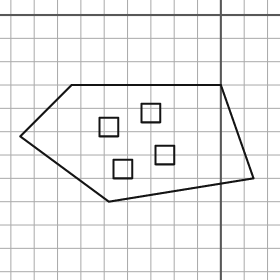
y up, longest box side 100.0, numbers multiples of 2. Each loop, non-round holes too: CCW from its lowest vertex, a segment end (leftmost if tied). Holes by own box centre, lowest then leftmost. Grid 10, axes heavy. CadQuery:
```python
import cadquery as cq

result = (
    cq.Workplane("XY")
    .moveTo(-48.0, -80.0)
    .lineTo(14.0, -70.0)
    .lineTo(0.0, -30.0)
    .lineTo(-64.0, -30.0)
    .lineTo(-86.0, -52.0)
    .close()
    .moveTo(-46.0, -70.0)
    .lineTo(-38.0, -70.0)
    .lineTo(-38.0, -62.0)
    .lineTo(-46.0, -62.0)
    .close()
    .moveTo(-28.0, -64.0)
    .lineTo(-20.0, -64.0)
    .lineTo(-20.0, -56.0)
    .lineTo(-28.0, -56.0)
    .close()
    .moveTo(-52.0, -52.0)
    .lineTo(-44.0, -52.0)
    .lineTo(-44.0, -44.0)
    .lineTo(-52.0, -44.0)
    .close()
    .moveTo(-34.0, -46.0)
    .lineTo(-26.0, -46.0)
    .lineTo(-26.0, -38.0)
    .lineTo(-34.0, -38.0)
    .close()
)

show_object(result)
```